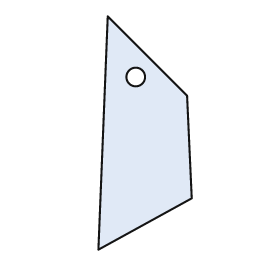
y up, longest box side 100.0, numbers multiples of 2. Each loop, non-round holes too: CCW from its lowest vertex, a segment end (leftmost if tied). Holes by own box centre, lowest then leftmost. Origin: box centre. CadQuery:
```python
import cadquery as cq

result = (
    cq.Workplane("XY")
    .moveTo(-20.0, -50.0)
    .lineTo(20.0, -28.0)
    .lineTo(18.0, 16.0)
    .lineTo(-16.0, 50.0)
    .close()
    .moveTo(-4.0, 24.0)
    .circle(4.0)
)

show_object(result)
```